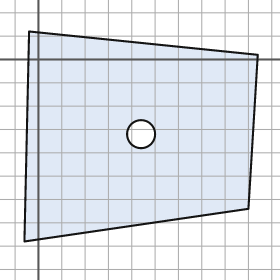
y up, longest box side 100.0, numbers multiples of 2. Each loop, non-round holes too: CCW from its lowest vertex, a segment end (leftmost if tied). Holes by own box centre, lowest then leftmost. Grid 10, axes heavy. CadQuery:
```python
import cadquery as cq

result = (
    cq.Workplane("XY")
    .moveTo(-6.0, -78.0)
    .lineTo(90.0, -64.0)
    .lineTo(94.0, 2.0)
    .lineTo(-4.0, 12.0)
    .close()
    .moveTo(44.0, -32.0)
    .circle(6.0)
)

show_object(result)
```